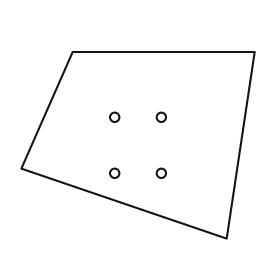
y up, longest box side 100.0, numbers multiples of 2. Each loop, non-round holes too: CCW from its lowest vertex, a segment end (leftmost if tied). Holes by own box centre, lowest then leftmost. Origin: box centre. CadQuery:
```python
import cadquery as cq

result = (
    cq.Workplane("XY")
    .moveTo(38.0, -40.0)
    .lineTo(50.0, 40.0)
    .lineTo(-28.0, 40.0)
    .lineTo(-50.0, -10.0)
    .close()
    .moveTo(-10.0, -12.0)
    .circle(2.0)
    .moveTo(10.0, -12.0)
    .circle(2.0)
    .moveTo(-10.0, 12.0)
    .circle(2.0)
    .moveTo(10.0, 12.0)
    .circle(2.0)
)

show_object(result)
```